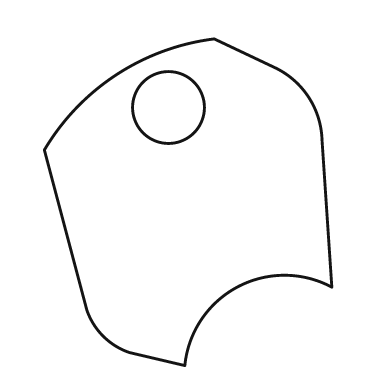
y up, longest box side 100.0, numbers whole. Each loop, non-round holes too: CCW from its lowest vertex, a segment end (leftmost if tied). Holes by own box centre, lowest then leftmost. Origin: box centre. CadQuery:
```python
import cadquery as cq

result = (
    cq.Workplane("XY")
    .moveTo(-1.0, -50.0)
    .threePointArc((15.0, -26.0), (44.0, -26.0))
    .lineTo(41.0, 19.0)
    .threePointArc((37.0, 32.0), (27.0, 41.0))
    .lineTo(8.0, 50.0)
    .threePointArc((-22.0, 39.0), (-44.0, 16.0))
    .lineTo(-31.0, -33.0)
    .threePointArc((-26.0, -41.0), (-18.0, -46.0))
    .close()
    .moveTo(-6.0, 29.0)
    .circle(11.0)
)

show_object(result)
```